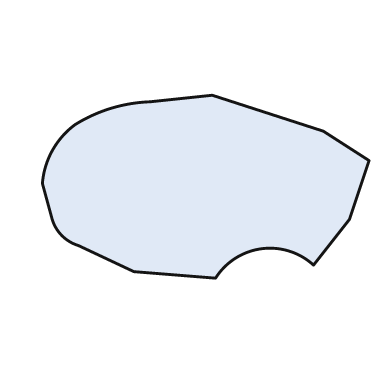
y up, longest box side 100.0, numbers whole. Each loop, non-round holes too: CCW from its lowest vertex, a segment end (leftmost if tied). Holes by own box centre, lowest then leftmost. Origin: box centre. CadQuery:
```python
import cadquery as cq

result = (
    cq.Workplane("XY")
    .moveTo(3.0, -28.0)
    .threePointArc((17.0, -19.0), (33.0, -24.0))
    .lineTo(44.0, -10.0)
    .lineTo(50.0, 8.0)
    .lineTo(36.0, 17.0)
    .lineTo(2.0, 28.0)
    .lineTo(-17.0, 26.0)
    .threePointArc((-29.0, 24.0), (-40.0, 19.0))
    .threePointArc((-47.0, 11.0), (-50.0, 1.0))
    .lineTo(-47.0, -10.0)
    .threePointArc((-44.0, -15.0), (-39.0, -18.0))
    .lineTo(-22.0, -26.0)
    .close()
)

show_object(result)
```